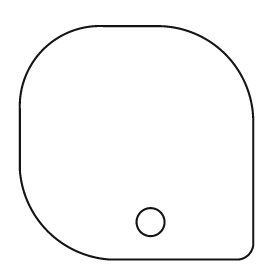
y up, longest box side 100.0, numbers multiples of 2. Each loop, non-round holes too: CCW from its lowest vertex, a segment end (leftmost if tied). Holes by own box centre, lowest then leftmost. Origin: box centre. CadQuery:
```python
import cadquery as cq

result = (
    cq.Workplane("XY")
    .moveTo(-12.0, -50.0)
    .lineTo(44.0, -50.0)
    .threePointArc((48.0, -48.0), (50.0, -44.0))
    .lineTo(50.0, 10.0)
    .threePointArc((38.0, 38.0), (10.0, 50.0))
    .lineTo(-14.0, 50.0)
    .threePointArc((-40.0, 40.0), (-50.0, 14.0))
    .lineTo(-50.0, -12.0)
    .threePointArc((-38.0, -38.0), (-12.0, -50.0))
    .close()
    .moveTo(6.0, -34.0)
    .circle(6.0)
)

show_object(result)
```